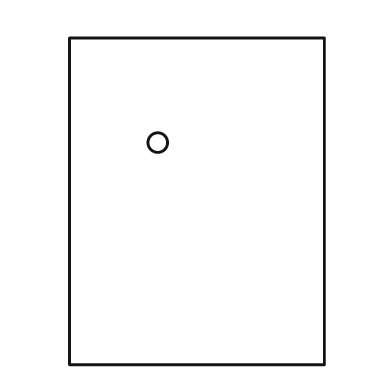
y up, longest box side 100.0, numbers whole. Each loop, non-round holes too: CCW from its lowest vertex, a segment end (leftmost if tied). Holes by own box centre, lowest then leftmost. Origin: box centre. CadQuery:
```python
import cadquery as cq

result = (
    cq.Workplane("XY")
    .moveTo(-39.0, -50.0)
    .lineTo(39.0, -50.0)
    .lineTo(39.0, 50.0)
    .lineTo(-39.0, 50.0)
    .close()
    .moveTo(-12.0, 18.0)
    .circle(3.0)
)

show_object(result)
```